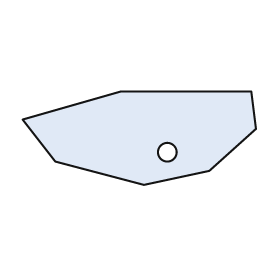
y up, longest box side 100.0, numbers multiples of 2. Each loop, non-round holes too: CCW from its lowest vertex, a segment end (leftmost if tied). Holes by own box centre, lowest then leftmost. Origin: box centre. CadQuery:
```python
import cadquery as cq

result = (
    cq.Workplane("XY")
    .moveTo(2.0, -20.0)
    .lineTo(30.0, -14.0)
    .lineTo(50.0, 4.0)
    .lineTo(48.0, 20.0)
    .lineTo(-8.0, 20.0)
    .lineTo(-50.0, 8.0)
    .lineTo(-36.0, -10.0)
    .close()
    .moveTo(12.0, -6.0)
    .circle(4.0)
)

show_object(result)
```